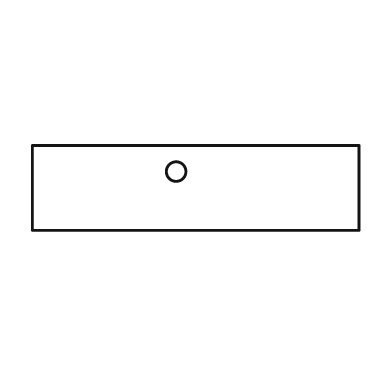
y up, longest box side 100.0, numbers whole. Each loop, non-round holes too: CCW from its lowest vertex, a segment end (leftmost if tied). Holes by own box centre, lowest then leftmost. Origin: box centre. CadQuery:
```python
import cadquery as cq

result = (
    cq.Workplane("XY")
    .moveTo(-50.0, -13.0)
    .lineTo(50.0, -13.0)
    .lineTo(50.0, 13.0)
    .lineTo(-50.0, 13.0)
    .close()
    .moveTo(-6.0, 5.0)
    .circle(3.0)
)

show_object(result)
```